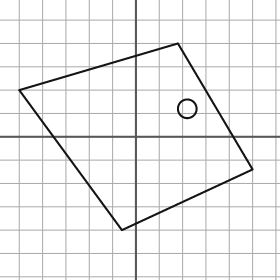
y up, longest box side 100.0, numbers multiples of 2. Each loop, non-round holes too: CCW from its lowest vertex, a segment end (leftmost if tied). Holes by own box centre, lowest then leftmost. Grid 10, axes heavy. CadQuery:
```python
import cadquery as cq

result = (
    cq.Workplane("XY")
    .moveTo(-6.0, -40.0)
    .lineTo(50.0, -14.0)
    .lineTo(18.0, 40.0)
    .lineTo(-50.0, 20.0)
    .close()
    .moveTo(22.0, 12.0)
    .circle(4.0)
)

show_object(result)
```